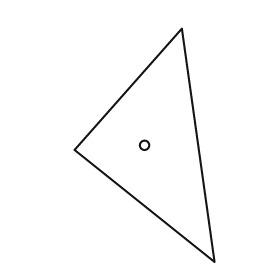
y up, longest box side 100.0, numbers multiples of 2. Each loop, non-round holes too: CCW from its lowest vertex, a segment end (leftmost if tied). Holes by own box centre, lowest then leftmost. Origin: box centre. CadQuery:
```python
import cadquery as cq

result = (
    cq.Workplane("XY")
    .moveTo(30.0, -50.0)
    .lineTo(16.0, 50.0)
    .lineTo(-30.0, -2.0)
    .close()
    .moveTo(0.0, 0.0)
    .circle(2.0)
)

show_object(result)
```